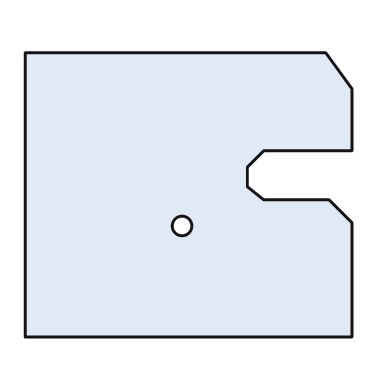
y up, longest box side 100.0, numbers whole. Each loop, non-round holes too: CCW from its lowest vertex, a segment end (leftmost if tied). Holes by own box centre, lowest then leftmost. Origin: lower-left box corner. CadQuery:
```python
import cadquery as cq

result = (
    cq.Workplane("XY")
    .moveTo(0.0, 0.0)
    .lineTo(100.0, 0.0)
    .lineTo(100.0, 35.0)
    .lineTo(93.0, 42.0)
    .lineTo(73.0, 42.0)
    .lineTo(68.0, 46.0)
    .lineTo(68.0, 52.0)
    .lineTo(73.0, 57.0)
    .lineTo(100.0, 57.0)
    .lineTo(100.0, 76.0)
    .lineTo(92.0, 87.0)
    .lineTo(0.0, 87.0)
    .close()
    .moveTo(48.0, 34.0)
    .circle(3.0)
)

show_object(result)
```